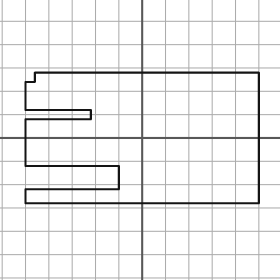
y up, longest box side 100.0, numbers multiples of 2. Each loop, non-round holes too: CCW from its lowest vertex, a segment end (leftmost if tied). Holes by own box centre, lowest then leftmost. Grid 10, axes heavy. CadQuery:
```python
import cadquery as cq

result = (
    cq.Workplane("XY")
    .moveTo(-50.0, -28.0)
    .lineTo(50.0, -28.0)
    .lineTo(50.0, 28.0)
    .lineTo(-46.0, 28.0)
    .lineTo(-46.0, 24.0)
    .lineTo(-50.0, 24.0)
    .lineTo(-50.0, 12.0)
    .lineTo(-22.0, 12.0)
    .lineTo(-22.0, 8.0)
    .lineTo(-50.0, 8.0)
    .lineTo(-50.0, -12.0)
    .lineTo(-10.0, -12.0)
    .lineTo(-10.0, -22.0)
    .lineTo(-50.0, -22.0)
    .close()
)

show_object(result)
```